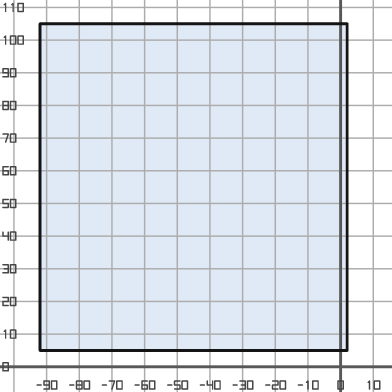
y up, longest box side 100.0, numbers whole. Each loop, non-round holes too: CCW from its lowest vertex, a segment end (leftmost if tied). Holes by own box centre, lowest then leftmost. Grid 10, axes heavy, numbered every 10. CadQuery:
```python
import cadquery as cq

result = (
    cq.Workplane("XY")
    .moveTo(-92.0, 5.0)
    .lineTo(2.0, 5.0)
    .lineTo(2.0, 105.0)
    .lineTo(-92.0, 105.0)
    .close()
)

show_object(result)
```